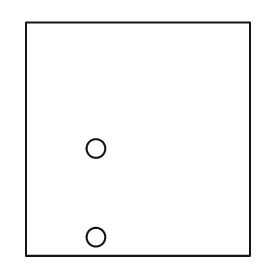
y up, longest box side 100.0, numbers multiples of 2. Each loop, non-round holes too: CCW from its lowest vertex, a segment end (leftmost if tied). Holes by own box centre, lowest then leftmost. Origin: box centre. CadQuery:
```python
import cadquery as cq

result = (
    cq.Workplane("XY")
    .moveTo(-48.0, -50.0)
    .lineTo(48.0, -50.0)
    .lineTo(48.0, 50.0)
    .lineTo(-48.0, 50.0)
    .close()
    .moveTo(-18.0, -42.0)
    .circle(4.0)
    .moveTo(-18.0, -4.0)
    .circle(4.0)
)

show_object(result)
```